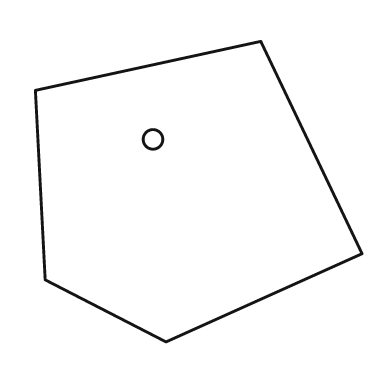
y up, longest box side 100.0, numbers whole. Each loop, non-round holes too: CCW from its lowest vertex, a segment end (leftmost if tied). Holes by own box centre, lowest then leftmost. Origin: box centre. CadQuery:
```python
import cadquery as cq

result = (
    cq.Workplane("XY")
    .moveTo(-10.0, -46.0)
    .lineTo(50.0, -19.0)
    .lineTo(19.0, 46.0)
    .lineTo(-50.0, 31.0)
    .lineTo(-47.0, -27.0)
    .close()
    .moveTo(-14.0, 16.0)
    .circle(3.0)
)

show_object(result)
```